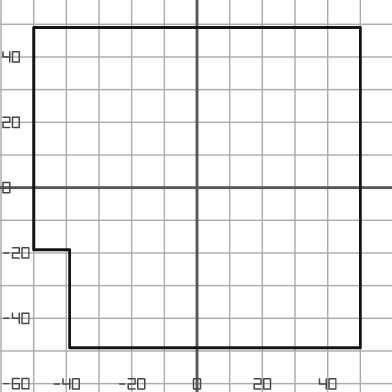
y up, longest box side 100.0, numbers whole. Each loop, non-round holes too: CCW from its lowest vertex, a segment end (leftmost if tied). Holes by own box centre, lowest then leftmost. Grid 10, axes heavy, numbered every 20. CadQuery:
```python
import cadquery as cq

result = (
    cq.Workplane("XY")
    .moveTo(-39.0, -49.0)
    .lineTo(50.0, -49.0)
    .lineTo(50.0, 49.0)
    .lineTo(-50.0, 49.0)
    .lineTo(-50.0, -19.0)
    .lineTo(-39.0, -19.0)
    .close()
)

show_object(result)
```